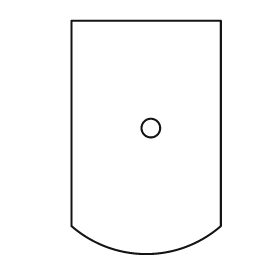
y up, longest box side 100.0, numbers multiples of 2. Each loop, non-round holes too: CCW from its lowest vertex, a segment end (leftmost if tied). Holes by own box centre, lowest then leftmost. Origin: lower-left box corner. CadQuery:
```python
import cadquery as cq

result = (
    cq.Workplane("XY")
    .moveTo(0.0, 12.0)
    .threePointArc((32.0, 0.0), (64.0, 12.0))
    .lineTo(64.0, 100.0)
    .lineTo(0.0, 100.0)
    .close()
    .moveTo(34.0, 54.0)
    .circle(4.0)
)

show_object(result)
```